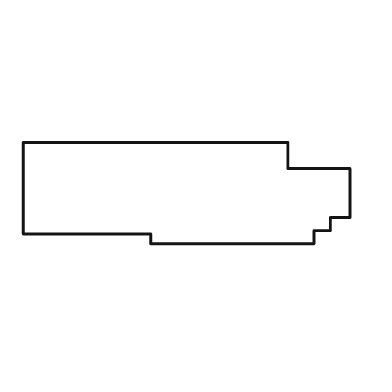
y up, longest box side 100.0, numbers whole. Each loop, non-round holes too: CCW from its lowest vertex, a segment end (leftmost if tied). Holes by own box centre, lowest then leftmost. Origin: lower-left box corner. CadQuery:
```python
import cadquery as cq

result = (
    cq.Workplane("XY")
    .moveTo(39.0, 0.0)
    .lineTo(89.0, 0.0)
    .lineTo(89.0, 4.0)
    .lineTo(94.0, 4.0)
    .lineTo(94.0, 8.0)
    .lineTo(100.0, 8.0)
    .lineTo(100.0, 23.0)
    .lineTo(81.0, 23.0)
    .lineTo(81.0, 31.0)
    .lineTo(0.0, 31.0)
    .lineTo(0.0, 3.0)
    .lineTo(39.0, 3.0)
    .close()
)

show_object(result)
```